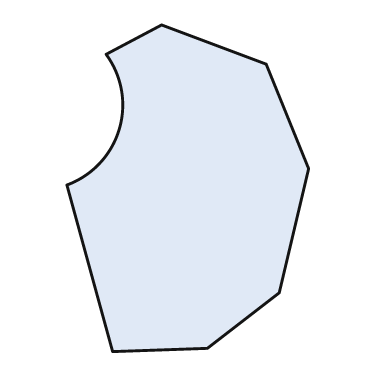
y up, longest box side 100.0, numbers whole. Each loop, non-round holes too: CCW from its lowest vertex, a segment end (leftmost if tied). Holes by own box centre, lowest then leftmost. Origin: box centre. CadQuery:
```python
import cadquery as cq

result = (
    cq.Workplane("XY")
    .moveTo(-23.0, -50.0)
    .lineTo(6.0, -49.0)
    .lineTo(28.0, -32.0)
    .lineTo(37.0, 6.0)
    .lineTo(24.0, 38.0)
    .lineTo(-8.0, 50.0)
    .lineTo(-25.0, 41.0)
    .threePointArc((-21.0, 18.0), (-37.0, 1.0))
    .close()
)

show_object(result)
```